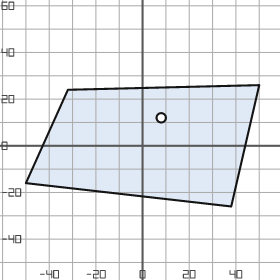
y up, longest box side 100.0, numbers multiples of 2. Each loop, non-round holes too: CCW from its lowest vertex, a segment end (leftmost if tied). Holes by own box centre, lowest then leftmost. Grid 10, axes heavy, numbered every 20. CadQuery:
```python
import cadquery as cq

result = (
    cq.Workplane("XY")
    .moveTo(38.0, -26.0)
    .lineTo(50.0, 26.0)
    .lineTo(-32.0, 24.0)
    .lineTo(-50.0, -16.0)
    .close()
    .moveTo(8.0, 12.0)
    .circle(2.0)
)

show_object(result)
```